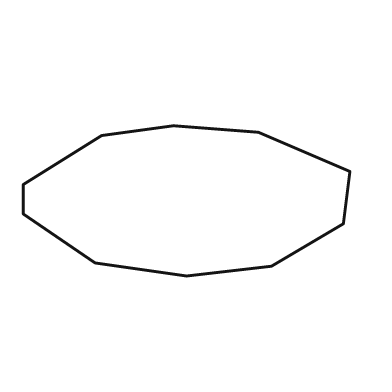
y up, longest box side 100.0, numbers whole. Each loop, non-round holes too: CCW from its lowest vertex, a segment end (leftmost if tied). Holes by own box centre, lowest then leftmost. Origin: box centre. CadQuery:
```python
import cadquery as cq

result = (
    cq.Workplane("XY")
    .moveTo(0.0, -23.0)
    .lineTo(26.0, -20.0)
    .lineTo(48.0, -7.0)
    .lineTo(50.0, 9.0)
    .lineTo(22.0, 21.0)
    .lineTo(-4.0, 23.0)
    .lineTo(-26.0, 20.0)
    .lineTo(-50.0, 5.0)
    .lineTo(-50.0, -4.0)
    .lineTo(-28.0, -19.0)
    .close()
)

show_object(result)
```